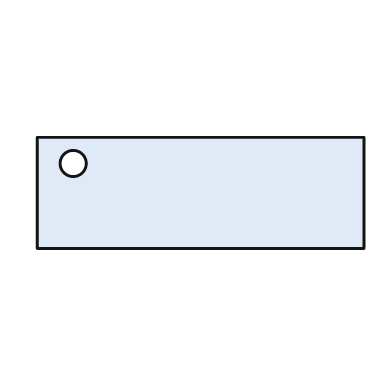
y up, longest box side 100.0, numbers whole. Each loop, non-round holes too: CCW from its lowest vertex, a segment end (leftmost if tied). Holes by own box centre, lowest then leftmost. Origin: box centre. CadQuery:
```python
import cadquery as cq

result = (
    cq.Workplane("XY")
    .moveTo(-50.0, -17.0)
    .lineTo(50.0, -17.0)
    .lineTo(50.0, 17.0)
    .lineTo(-50.0, 17.0)
    .close()
    .moveTo(-39.0, 9.0)
    .circle(4.0)
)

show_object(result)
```